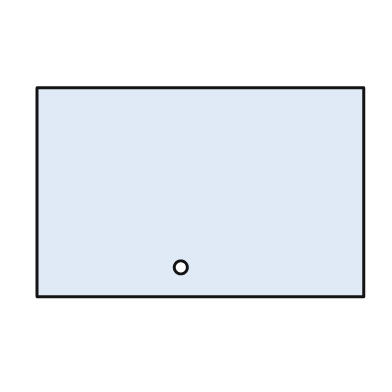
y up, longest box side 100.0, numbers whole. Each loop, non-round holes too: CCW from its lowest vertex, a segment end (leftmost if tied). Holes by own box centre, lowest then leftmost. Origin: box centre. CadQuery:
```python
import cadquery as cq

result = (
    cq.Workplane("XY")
    .moveTo(-50.0, -32.0)
    .lineTo(50.0, -32.0)
    .lineTo(50.0, 32.0)
    .lineTo(-50.0, 32.0)
    .close()
    .moveTo(-6.0, -23.0)
    .circle(2.0)
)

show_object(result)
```